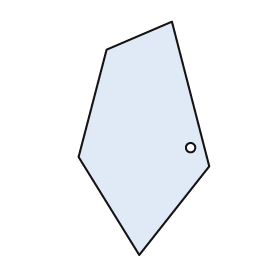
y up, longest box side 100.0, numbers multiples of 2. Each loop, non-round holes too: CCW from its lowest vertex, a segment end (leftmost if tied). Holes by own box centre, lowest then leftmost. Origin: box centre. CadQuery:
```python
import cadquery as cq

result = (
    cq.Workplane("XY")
    .moveTo(-2.0, -50.0)
    .lineTo(28.0, -12.0)
    .lineTo(12.0, 50.0)
    .lineTo(-16.0, 38.0)
    .lineTo(-28.0, -8.0)
    .close()
    .moveTo(20.0, -4.0)
    .circle(2.0)
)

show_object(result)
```